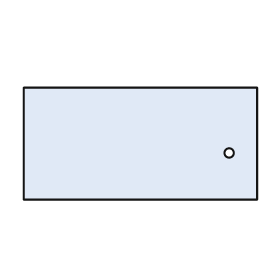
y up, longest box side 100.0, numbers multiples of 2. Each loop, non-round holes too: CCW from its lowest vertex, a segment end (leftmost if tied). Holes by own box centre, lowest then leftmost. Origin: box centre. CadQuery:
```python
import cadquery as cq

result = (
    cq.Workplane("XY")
    .moveTo(-50.0, -24.0)
    .lineTo(50.0, -24.0)
    .lineTo(50.0, 24.0)
    .lineTo(-50.0, 24.0)
    .close()
    .moveTo(38.0, -4.0)
    .circle(2.0)
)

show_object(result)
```